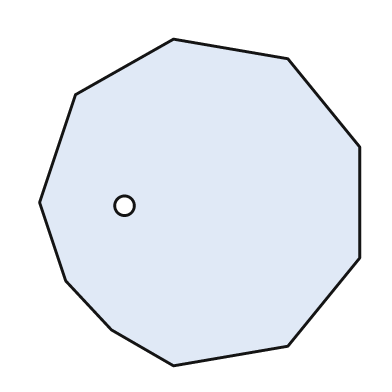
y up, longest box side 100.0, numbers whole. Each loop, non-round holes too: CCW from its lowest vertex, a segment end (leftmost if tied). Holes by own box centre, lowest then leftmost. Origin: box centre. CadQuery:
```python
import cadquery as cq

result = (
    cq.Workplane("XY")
    .moveTo(-8.0, -50.0)
    .lineTo(27.0, -44.0)
    .lineTo(49.0, -17.0)
    .lineTo(49.0, 17.0)
    .lineTo(27.0, 44.0)
    .lineTo(-8.0, 50.0)
    .lineTo(-38.0, 33.0)
    .lineTo(-49.0, 0.0)
    .lineTo(-41.0, -24.0)
    .lineTo(-27.0, -39.0)
    .close()
    .moveTo(-23.0, -1.0)
    .circle(3.0)
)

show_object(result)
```